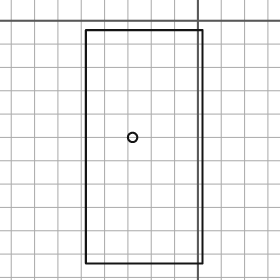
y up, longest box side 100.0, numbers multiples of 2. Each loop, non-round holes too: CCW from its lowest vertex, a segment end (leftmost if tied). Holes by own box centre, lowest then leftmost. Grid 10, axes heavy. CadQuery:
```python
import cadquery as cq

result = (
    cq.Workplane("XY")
    .moveTo(-48.0, -104.0)
    .lineTo(2.0, -104.0)
    .lineTo(2.0, -4.0)
    .lineTo(-48.0, -4.0)
    .close()
    .moveTo(-28.0, -50.0)
    .circle(2.0)
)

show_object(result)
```